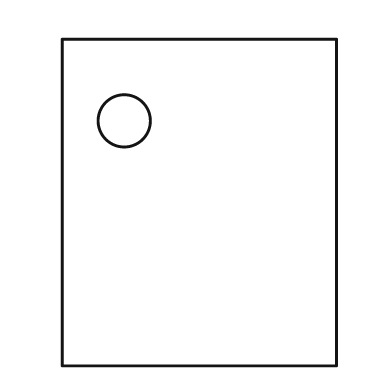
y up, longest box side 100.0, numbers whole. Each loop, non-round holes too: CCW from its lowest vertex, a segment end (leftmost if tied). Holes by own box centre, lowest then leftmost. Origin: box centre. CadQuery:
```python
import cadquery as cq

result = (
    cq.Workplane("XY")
    .moveTo(-42.0, -50.0)
    .lineTo(42.0, -50.0)
    .lineTo(42.0, 50.0)
    .lineTo(-42.0, 50.0)
    .close()
    .moveTo(-23.0, 25.0)
    .circle(8.0)
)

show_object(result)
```